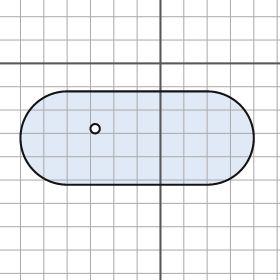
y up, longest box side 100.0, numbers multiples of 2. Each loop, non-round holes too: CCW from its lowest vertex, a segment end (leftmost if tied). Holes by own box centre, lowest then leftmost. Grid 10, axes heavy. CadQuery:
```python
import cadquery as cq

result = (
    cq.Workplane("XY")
    .moveTo(-40.0, -52.0)
    .lineTo(20.0, -52.0)
    .threePointArc((40.0, -32.0), (20.0, -12.0))
    .lineTo(-40.0, -12.0)
    .threePointArc((-60.0, -32.0), (-40.0, -52.0))
    .close()
    .moveTo(-28.0, -28.0)
    .circle(2.0)
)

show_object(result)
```